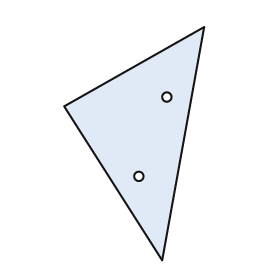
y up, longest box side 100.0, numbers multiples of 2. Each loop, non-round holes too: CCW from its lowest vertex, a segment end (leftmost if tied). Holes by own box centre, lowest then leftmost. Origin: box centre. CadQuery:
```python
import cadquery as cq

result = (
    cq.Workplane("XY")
    .moveTo(12.0, -50.0)
    .lineTo(30.0, 50.0)
    .lineTo(-30.0, 16.0)
    .close()
    .moveTo(2.0, -14.0)
    .circle(2.0)
    .moveTo(14.0, 20.0)
    .circle(2.0)
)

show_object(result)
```